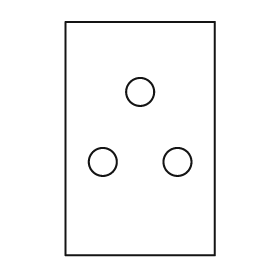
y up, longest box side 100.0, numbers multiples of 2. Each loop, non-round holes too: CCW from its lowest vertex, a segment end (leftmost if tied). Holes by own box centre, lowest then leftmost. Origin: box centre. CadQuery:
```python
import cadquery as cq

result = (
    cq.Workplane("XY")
    .moveTo(-32.0, -50.0)
    .lineTo(32.0, -50.0)
    .lineTo(32.0, 50.0)
    .lineTo(-32.0, 50.0)
    .close()
    .moveTo(-16.0, -10.0)
    .circle(6.0)
    .moveTo(16.0, -10.0)
    .circle(6.0)
    .moveTo(0.0, 20.0)
    .circle(6.0)
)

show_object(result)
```